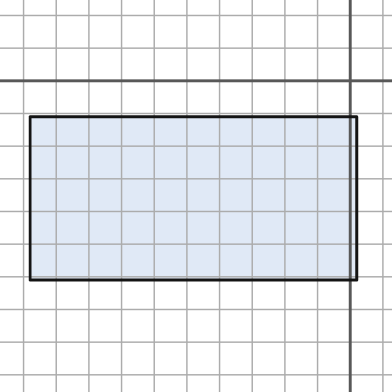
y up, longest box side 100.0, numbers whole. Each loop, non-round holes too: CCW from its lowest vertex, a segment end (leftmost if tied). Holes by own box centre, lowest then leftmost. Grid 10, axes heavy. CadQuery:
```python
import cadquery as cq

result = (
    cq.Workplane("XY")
    .moveTo(-98.0, -61.0)
    .lineTo(2.0, -61.0)
    .lineTo(2.0, -11.0)
    .lineTo(-98.0, -11.0)
    .close()
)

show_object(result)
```